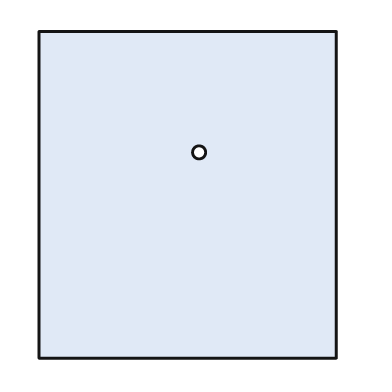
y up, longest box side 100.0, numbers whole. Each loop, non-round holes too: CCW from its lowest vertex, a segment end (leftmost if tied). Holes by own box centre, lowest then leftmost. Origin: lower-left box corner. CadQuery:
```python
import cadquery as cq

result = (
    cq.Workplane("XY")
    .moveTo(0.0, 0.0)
    .lineTo(91.0, 0.0)
    .lineTo(91.0, 100.0)
    .lineTo(0.0, 100.0)
    .close()
    .moveTo(49.0, 63.0)
    .circle(2.0)
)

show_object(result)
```